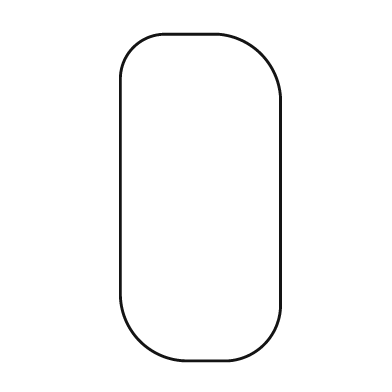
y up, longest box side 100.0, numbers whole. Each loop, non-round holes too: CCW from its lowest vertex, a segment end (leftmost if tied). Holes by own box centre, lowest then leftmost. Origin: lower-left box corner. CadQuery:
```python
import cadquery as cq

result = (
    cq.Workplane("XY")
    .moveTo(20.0, 0.0)
    .lineTo(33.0, 0.0)
    .threePointArc((44.0, 5.0), (49.0, 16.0))
    .lineTo(49.0, 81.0)
    .threePointArc((43.0, 94.0), (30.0, 100.0))
    .lineTo(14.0, 100.0)
    .threePointArc((4.0, 96.0), (0.0, 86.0))
    .lineTo(0.0, 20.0)
    .threePointArc((6.0, 6.0), (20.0, 0.0))
    .close()
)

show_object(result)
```